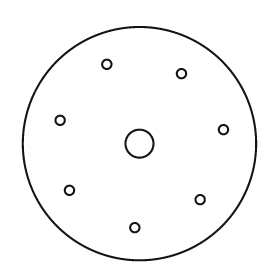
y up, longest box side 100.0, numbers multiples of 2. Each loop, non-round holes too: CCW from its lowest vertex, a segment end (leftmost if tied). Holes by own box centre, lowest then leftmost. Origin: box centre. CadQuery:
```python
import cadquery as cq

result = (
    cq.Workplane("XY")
    .moveTo(0.0, 0.0)
    .circle(50.0)
    .moveTo(-2.0, -36.0)
    .circle(2.0)
    .moveTo(26.0, -24.0)
    .circle(2.0)
    .moveTo(-30.0, -20.0)
    .circle(2.0)
    .moveTo(0.0, 0.0)
    .circle(6.0)
    .moveTo(36.0, 6.0)
    .circle(2.0)
    .moveTo(-34.0, 10.0)
    .circle(2.0)
    .moveTo(18.0, 30.0)
    .circle(2.0)
    .moveTo(-14.0, 34.0)
    .circle(2.0)
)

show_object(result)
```